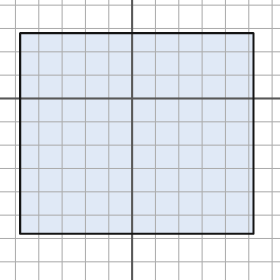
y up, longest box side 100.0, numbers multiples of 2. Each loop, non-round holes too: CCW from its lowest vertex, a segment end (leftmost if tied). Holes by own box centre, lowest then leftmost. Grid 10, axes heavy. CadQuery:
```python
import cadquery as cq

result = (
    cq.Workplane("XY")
    .moveTo(-48.0, -58.0)
    .lineTo(52.0, -58.0)
    .lineTo(52.0, 28.0)
    .lineTo(-48.0, 28.0)
    .close()
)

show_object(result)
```